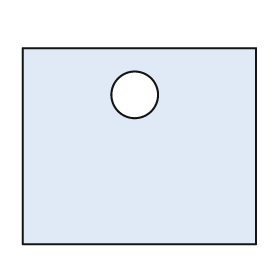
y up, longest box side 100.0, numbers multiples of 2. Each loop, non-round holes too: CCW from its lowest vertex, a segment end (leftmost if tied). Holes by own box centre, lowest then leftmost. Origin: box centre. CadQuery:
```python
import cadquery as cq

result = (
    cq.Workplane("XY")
    .moveTo(-50.0, -42.0)
    .lineTo(50.0, -42.0)
    .lineTo(50.0, 42.0)
    .lineTo(-50.0, 42.0)
    .close()
    .moveTo(-2.0, 22.0)
    .circle(10.0)
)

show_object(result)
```